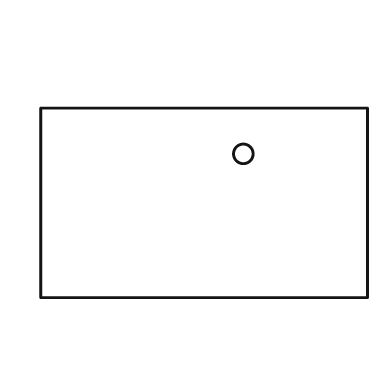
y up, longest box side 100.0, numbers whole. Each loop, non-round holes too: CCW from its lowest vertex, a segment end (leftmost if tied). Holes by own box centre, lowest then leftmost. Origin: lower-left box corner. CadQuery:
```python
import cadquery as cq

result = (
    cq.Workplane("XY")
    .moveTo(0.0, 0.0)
    .lineTo(100.0, 0.0)
    .lineTo(100.0, 58.0)
    .lineTo(0.0, 58.0)
    .close()
    .moveTo(62.0, 44.0)
    .circle(3.0)
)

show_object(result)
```